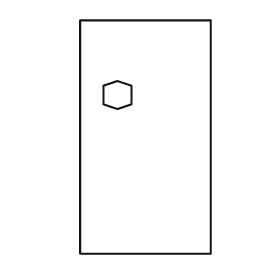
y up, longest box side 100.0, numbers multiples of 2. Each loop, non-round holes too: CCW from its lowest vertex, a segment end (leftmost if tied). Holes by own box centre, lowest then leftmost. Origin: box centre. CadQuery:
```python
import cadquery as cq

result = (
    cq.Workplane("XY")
    .moveTo(-28.0, -50.0)
    .lineTo(28.0, -50.0)
    .lineTo(28.0, 50.0)
    .lineTo(-28.0, 50.0)
    .close()
    .moveTo(-12.0, 12.0)
    .lineTo(-6.0, 14.0)
    .lineTo(-6.0, 22.0)
    .lineTo(-12.0, 24.0)
    .lineTo(-18.0, 22.0)
    .lineTo(-18.0, 14.0)
    .close()
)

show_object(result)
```